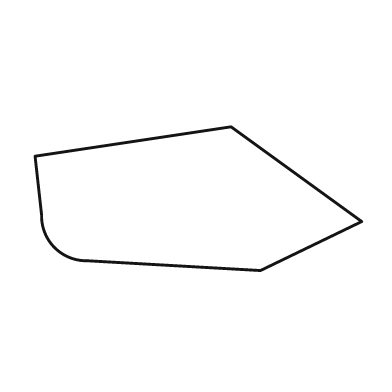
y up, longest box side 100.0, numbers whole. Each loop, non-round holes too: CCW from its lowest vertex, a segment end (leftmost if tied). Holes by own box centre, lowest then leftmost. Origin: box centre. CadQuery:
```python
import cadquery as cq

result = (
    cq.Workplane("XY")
    .moveTo(19.0, -22.0)
    .lineTo(50.0, -7.0)
    .lineTo(10.0, 22.0)
    .lineTo(-50.0, 13.0)
    .lineTo(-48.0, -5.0)
    .threePointArc((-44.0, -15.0), (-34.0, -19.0))
    .close()
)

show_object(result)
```